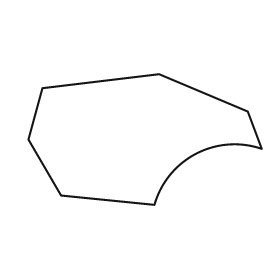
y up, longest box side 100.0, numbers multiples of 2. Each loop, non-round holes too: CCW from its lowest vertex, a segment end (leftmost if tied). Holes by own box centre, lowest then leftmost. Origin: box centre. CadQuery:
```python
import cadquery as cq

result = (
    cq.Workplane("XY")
    .moveTo(4.0, -28.0)
    .threePointArc((22.0, -6.0), (50.0, -4.0))
    .lineTo(44.0, 12.0)
    .lineTo(6.0, 28.0)
    .lineTo(-44.0, 22.0)
    .lineTo(-50.0, 0.0)
    .lineTo(-36.0, -24.0)
    .close()
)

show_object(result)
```